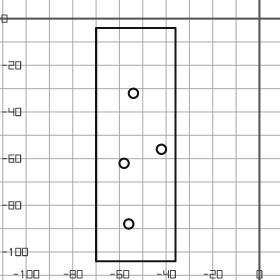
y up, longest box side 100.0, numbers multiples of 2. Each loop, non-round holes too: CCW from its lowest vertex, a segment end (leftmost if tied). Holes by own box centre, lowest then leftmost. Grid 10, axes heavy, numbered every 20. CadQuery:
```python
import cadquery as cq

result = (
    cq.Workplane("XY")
    .moveTo(-70.0, -104.0)
    .lineTo(-36.0, -104.0)
    .lineTo(-36.0, -4.0)
    .lineTo(-70.0, -4.0)
    .close()
    .moveTo(-56.0, -88.0)
    .circle(2.0)
    .moveTo(-58.0, -62.0)
    .circle(2.0)
    .moveTo(-42.0, -56.0)
    .circle(2.0)
    .moveTo(-54.0, -32.0)
    .circle(2.0)
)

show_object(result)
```